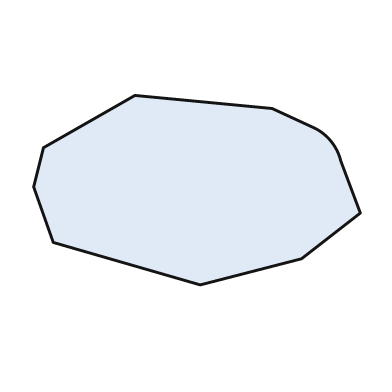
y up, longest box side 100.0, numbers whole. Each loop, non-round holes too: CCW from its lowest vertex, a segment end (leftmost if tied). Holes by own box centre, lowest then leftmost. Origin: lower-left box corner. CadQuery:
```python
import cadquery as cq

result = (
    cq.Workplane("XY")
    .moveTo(51.0, 0.0)
    .lineTo(82.0, 8.0)
    .lineTo(100.0, 22.0)
    .lineTo(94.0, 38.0)
    .threePointArc((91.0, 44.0), (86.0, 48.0))
    .lineTo(73.0, 54.0)
    .lineTo(31.0, 58.0)
    .lineTo(3.0, 42.0)
    .lineTo(0.0, 30.0)
    .lineTo(6.0, 13.0)
    .close()
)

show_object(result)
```